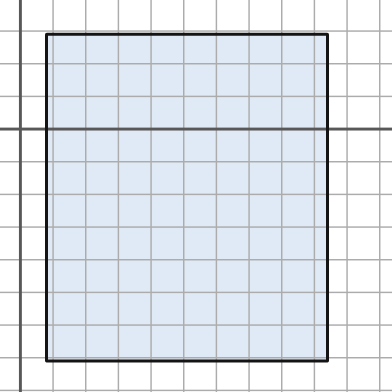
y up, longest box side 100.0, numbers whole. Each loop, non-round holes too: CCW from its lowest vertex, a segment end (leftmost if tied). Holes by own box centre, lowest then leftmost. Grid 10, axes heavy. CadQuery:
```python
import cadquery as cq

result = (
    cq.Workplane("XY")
    .moveTo(8.0, -71.0)
    .lineTo(94.0, -71.0)
    .lineTo(94.0, 29.0)
    .lineTo(8.0, 29.0)
    .close()
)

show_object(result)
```